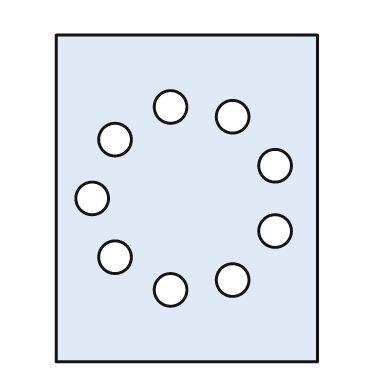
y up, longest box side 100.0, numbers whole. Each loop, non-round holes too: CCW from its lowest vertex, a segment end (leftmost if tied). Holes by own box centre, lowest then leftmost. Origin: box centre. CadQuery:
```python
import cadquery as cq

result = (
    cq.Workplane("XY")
    .moveTo(-40.0, -50.0)
    .lineTo(40.0, -50.0)
    .lineTo(40.0, 50.0)
    .lineTo(-40.0, 50.0)
    .close()
    .moveTo(-5.0, -28.0)
    .circle(5.0)
    .moveTo(14.0, -25.0)
    .circle(5.0)
    .moveTo(-22.0, -18.0)
    .circle(5.0)
    .moveTo(27.0, -10.0)
    .circle(5.0)
    .moveTo(-29.0, 0.0)
    .circle(5.0)
    .moveTo(27.0, 10.0)
    .circle(5.0)
    .moveTo(-22.0, 18.0)
    .circle(5.0)
    .moveTo(14.0, 25.0)
    .circle(5.0)
    .moveTo(-5.0, 28.0)
    .circle(5.0)
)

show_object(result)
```